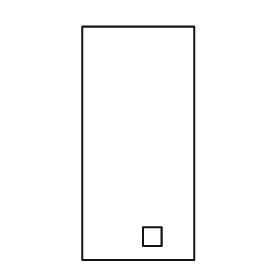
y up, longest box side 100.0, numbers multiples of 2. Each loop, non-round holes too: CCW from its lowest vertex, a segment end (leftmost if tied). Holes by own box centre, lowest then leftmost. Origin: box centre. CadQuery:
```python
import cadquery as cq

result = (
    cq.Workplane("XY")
    .moveTo(-24.0, -50.0)
    .lineTo(24.0, -50.0)
    .lineTo(24.0, 50.0)
    .lineTo(-24.0, 50.0)
    .close()
    .moveTo(2.0, -44.0)
    .lineTo(10.0, -44.0)
    .lineTo(10.0, -36.0)
    .lineTo(2.0, -36.0)
    .close()
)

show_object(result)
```